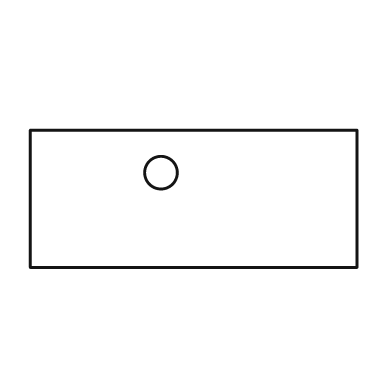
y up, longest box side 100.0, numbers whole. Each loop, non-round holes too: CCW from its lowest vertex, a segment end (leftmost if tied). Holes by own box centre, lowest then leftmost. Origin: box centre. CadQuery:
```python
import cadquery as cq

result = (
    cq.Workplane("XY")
    .moveTo(-50.0, -21.0)
    .lineTo(50.0, -21.0)
    .lineTo(50.0, 21.0)
    .lineTo(-50.0, 21.0)
    .close()
    .moveTo(-10.0, 8.0)
    .circle(5.0)
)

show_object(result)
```